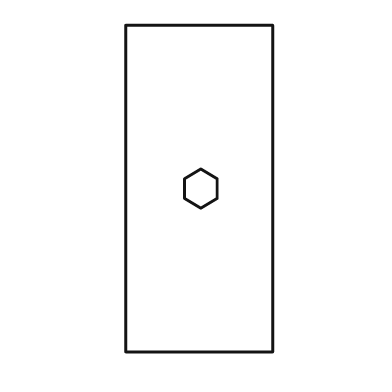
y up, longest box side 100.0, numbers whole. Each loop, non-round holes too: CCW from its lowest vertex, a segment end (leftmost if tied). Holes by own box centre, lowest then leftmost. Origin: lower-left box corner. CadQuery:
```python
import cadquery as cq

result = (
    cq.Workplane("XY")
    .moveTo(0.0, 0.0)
    .lineTo(45.0, 0.0)
    .lineTo(45.0, 100.0)
    .lineTo(0.0, 100.0)
    .close()
    .moveTo(23.0, 44.0)
    .lineTo(28.0, 47.0)
    .lineTo(28.0, 53.0)
    .lineTo(23.0, 56.0)
    .lineTo(18.0, 53.0)
    .lineTo(18.0, 47.0)
    .close()
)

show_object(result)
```